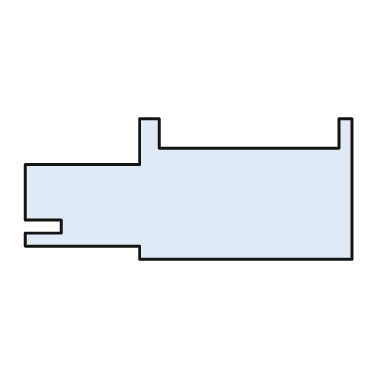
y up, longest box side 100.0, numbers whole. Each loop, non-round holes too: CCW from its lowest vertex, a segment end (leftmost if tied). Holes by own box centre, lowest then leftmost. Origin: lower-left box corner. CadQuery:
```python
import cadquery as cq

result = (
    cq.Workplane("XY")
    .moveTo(35.0, 0.0)
    .lineTo(100.0, 0.0)
    .lineTo(100.0, 43.0)
    .lineTo(96.0, 43.0)
    .lineTo(96.0, 34.0)
    .lineTo(41.0, 34.0)
    .lineTo(41.0, 43.0)
    .lineTo(35.0, 43.0)
    .lineTo(35.0, 29.0)
    .lineTo(0.0, 29.0)
    .lineTo(0.0, 12.0)
    .lineTo(11.0, 12.0)
    .lineTo(11.0, 8.0)
    .lineTo(0.0, 8.0)
    .lineTo(0.0, 4.0)
    .lineTo(35.0, 4.0)
    .close()
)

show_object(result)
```